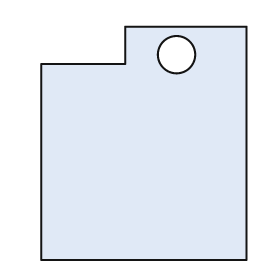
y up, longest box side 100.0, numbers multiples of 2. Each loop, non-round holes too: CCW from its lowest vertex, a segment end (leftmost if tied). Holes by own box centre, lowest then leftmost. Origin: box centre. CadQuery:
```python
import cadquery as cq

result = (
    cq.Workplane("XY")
    .moveTo(-44.0, -50.0)
    .lineTo(44.0, -50.0)
    .lineTo(44.0, 50.0)
    .lineTo(-8.0, 50.0)
    .lineTo(-8.0, 34.0)
    .lineTo(-44.0, 34.0)
    .close()
    .moveTo(14.0, 38.0)
    .circle(8.0)
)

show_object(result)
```